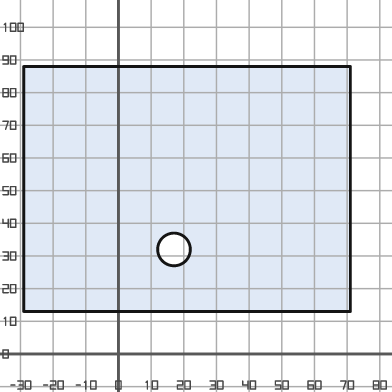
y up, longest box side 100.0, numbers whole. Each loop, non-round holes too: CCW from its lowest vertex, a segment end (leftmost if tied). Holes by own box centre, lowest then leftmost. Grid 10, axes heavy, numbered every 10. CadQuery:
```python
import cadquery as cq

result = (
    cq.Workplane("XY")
    .moveTo(-29.0, 13.0)
    .lineTo(71.0, 13.0)
    .lineTo(71.0, 88.0)
    .lineTo(-29.0, 88.0)
    .close()
    .moveTo(17.0, 32.0)
    .circle(5.0)
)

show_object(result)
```